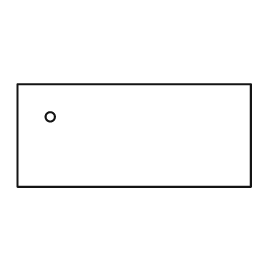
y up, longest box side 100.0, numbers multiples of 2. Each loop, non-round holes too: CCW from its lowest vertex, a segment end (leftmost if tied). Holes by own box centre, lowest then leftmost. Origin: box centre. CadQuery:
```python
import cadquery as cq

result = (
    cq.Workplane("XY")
    .moveTo(-50.0, -22.0)
    .lineTo(50.0, -22.0)
    .lineTo(50.0, 22.0)
    .lineTo(-50.0, 22.0)
    .close()
    .moveTo(-36.0, 8.0)
    .circle(2.0)
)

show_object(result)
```